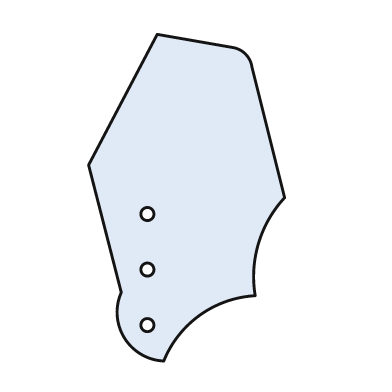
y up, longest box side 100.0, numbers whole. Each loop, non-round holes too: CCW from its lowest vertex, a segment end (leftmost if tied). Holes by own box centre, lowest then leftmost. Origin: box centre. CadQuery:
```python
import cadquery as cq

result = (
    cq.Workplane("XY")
    .moveTo(-7.0, -50.0)
    .threePointArc((4.0, -36.0), (21.0, -30.0))
    .threePointArc((22.0, -14.0), (30.0, 0.0))
    .lineTo(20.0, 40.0)
    .threePointArc((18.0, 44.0), (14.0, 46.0))
    .lineTo(-9.0, 50.0)
    .lineTo(-30.0, 10.0)
    .lineTo(-20.0, -29.0)
    .threePointArc((-19.0, -43.0), (-7.0, -50.0))
    .close()
    .moveTo(-12.0, -39.0)
    .circle(2.0)
    .moveTo(-12.0, -22.0)
    .circle(2.0)
    .moveTo(-12.0, -5.0)
    .circle(2.0)
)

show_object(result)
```